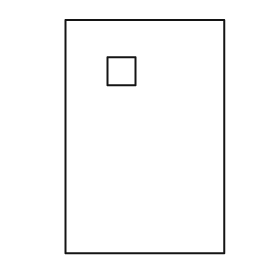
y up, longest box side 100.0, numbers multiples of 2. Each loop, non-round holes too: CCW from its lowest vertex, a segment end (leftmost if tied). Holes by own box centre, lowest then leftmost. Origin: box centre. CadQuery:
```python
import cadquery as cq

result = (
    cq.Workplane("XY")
    .moveTo(-34.0, -50.0)
    .lineTo(34.0, -50.0)
    .lineTo(34.0, 50.0)
    .lineTo(-34.0, 50.0)
    .close()
    .moveTo(-16.0, 22.0)
    .lineTo(-4.0, 22.0)
    .lineTo(-4.0, 34.0)
    .lineTo(-16.0, 34.0)
    .close()
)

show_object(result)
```